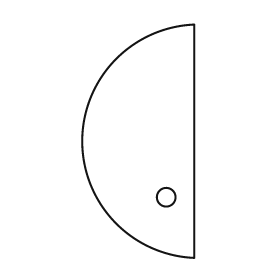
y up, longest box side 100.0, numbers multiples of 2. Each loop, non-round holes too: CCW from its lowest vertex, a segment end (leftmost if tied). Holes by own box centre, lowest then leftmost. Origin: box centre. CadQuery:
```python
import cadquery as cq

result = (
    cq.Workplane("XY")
    .moveTo(24.0, -50.0)
    .lineTo(24.0, 50.0)
    .threePointArc((-24.0, 0.0), (24.0, -50.0))
    .close()
    .moveTo(12.0, -24.0)
    .circle(4.0)
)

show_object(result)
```